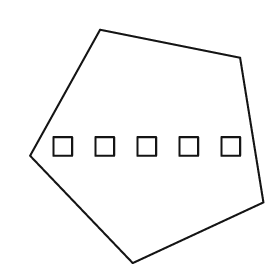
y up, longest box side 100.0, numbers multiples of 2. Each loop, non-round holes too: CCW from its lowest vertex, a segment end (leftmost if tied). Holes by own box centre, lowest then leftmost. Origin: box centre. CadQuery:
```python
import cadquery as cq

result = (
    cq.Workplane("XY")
    .moveTo(-6.0, -50.0)
    .lineTo(50.0, -24.0)
    .lineTo(40.0, 38.0)
    .lineTo(-20.0, 50.0)
    .lineTo(-50.0, -4.0)
    .close()
    .moveTo(-40.0, -4.0)
    .lineTo(-32.0, -4.0)
    .lineTo(-32.0, 4.0)
    .lineTo(-40.0, 4.0)
    .close()
    .moveTo(-22.0, -4.0)
    .lineTo(-14.0, -4.0)
    .lineTo(-14.0, 4.0)
    .lineTo(-22.0, 4.0)
    .close()
    .moveTo(-4.0, -4.0)
    .lineTo(4.0, -4.0)
    .lineTo(4.0, 4.0)
    .lineTo(-4.0, 4.0)
    .close()
    .moveTo(14.0, -4.0)
    .lineTo(22.0, -4.0)
    .lineTo(22.0, 4.0)
    .lineTo(14.0, 4.0)
    .close()
    .moveTo(32.0, -4.0)
    .lineTo(40.0, -4.0)
    .lineTo(40.0, 4.0)
    .lineTo(32.0, 4.0)
    .close()
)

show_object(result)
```